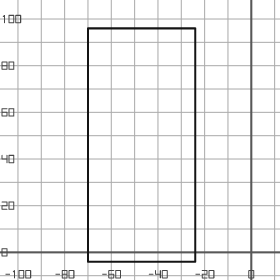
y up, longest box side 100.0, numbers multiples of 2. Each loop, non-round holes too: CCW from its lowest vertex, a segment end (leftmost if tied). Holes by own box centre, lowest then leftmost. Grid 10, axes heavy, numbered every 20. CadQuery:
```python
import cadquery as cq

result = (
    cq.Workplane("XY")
    .moveTo(-70.0, -4.0)
    .lineTo(-24.0, -4.0)
    .lineTo(-24.0, 96.0)
    .lineTo(-70.0, 96.0)
    .close()
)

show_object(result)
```